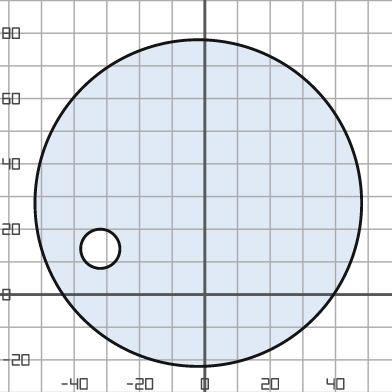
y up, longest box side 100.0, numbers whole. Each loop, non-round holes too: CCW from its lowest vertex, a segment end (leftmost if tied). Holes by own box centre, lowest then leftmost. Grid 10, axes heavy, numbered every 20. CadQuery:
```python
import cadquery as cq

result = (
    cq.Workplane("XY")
    .moveTo(-2.0, 28.0)
    .circle(50.0)
    .moveTo(-32.0, 14.0)
    .circle(6.0)
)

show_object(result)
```